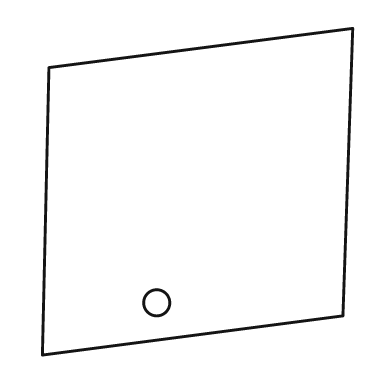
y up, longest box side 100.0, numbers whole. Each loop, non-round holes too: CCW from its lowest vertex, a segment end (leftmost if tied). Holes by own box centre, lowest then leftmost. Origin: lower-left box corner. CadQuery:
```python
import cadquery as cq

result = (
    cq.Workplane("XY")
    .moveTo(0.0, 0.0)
    .lineTo(92.0, 12.0)
    .lineTo(95.0, 100.0)
    .lineTo(2.0, 88.0)
    .close()
    .moveTo(35.0, 16.0)
    .circle(4.0)
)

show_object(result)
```